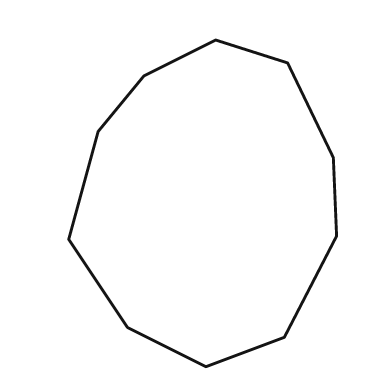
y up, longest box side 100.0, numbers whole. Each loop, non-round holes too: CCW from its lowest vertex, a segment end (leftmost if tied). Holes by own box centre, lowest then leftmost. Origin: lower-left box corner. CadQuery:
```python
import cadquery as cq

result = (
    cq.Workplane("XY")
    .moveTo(42.0, 0.0)
    .lineTo(66.0, 9.0)
    .lineTo(82.0, 40.0)
    .lineTo(81.0, 64.0)
    .lineTo(67.0, 93.0)
    .lineTo(45.0, 100.0)
    .lineTo(23.0, 89.0)
    .lineTo(9.0, 72.0)
    .lineTo(0.0, 39.0)
    .lineTo(18.0, 12.0)
    .close()
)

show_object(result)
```